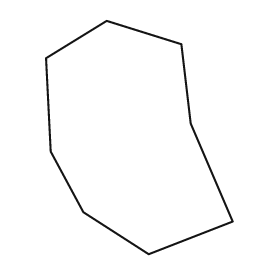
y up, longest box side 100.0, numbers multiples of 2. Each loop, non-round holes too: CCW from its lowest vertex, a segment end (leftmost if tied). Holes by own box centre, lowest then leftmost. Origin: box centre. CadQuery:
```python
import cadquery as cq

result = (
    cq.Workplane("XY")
    .moveTo(4.0, -50.0)
    .lineTo(40.0, -36.0)
    .lineTo(22.0, 6.0)
    .lineTo(18.0, 40.0)
    .lineTo(-14.0, 50.0)
    .lineTo(-40.0, 34.0)
    .lineTo(-38.0, -6.0)
    .lineTo(-24.0, -32.0)
    .close()
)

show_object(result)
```